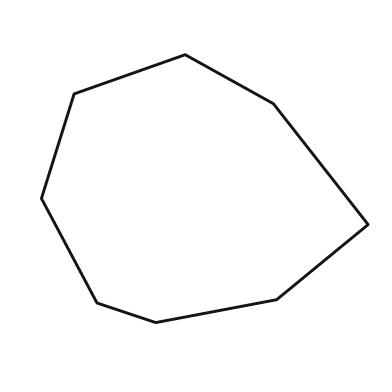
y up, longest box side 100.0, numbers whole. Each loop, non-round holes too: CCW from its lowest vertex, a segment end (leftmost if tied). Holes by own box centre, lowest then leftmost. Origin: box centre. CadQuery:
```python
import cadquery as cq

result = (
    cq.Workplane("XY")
    .moveTo(-15.0, -41.0)
    .lineTo(22.0, -34.0)
    .lineTo(50.0, -11.0)
    .lineTo(21.0, 26.0)
    .lineTo(-6.0, 41.0)
    .lineTo(-40.0, 29.0)
    .lineTo(-50.0, -3.0)
    .lineTo(-33.0, -35.0)
    .close()
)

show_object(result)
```